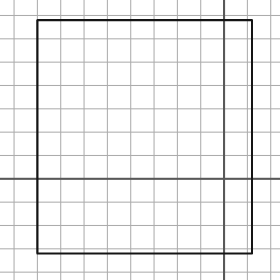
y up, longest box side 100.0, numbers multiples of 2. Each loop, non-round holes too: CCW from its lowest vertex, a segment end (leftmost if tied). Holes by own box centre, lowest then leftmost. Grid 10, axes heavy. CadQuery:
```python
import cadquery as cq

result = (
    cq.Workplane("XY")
    .moveTo(-80.0, -32.0)
    .lineTo(12.0, -32.0)
    .lineTo(12.0, 68.0)
    .lineTo(-80.0, 68.0)
    .close()
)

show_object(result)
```